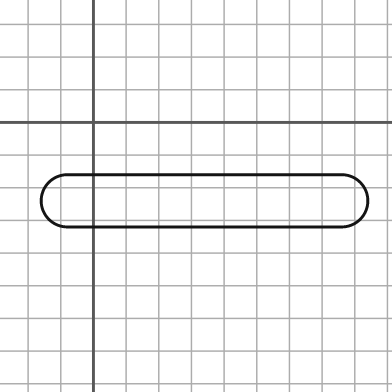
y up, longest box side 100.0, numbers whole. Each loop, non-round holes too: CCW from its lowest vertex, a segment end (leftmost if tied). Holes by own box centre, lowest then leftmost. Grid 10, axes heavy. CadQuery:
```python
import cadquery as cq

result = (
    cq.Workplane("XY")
    .moveTo(-8.0, -32.0)
    .lineTo(76.0, -32.0)
    .threePointArc((84.0, -24.0), (76.0, -16.0))
    .lineTo(-8.0, -16.0)
    .threePointArc((-16.0, -24.0), (-8.0, -32.0))
    .close()
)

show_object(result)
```